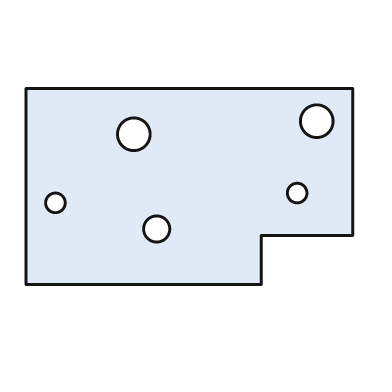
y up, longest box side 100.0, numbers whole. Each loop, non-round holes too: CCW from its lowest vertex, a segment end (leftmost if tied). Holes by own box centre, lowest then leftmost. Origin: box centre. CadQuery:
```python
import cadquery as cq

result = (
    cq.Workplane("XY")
    .moveTo(-50.0, -30.0)
    .lineTo(22.0, -30.0)
    .lineTo(22.0, -15.0)
    .lineTo(50.0, -15.0)
    .lineTo(50.0, 30.0)
    .lineTo(-50.0, 30.0)
    .close()
    .moveTo(-10.0, -13.0)
    .circle(4.0)
    .moveTo(-41.0, -5.0)
    .circle(3.0)
    .moveTo(33.0, -2.0)
    .circle(3.0)
    .moveTo(-17.0, 16.0)
    .circle(5.0)
    .moveTo(39.0, 20.0)
    .circle(5.0)
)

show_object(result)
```